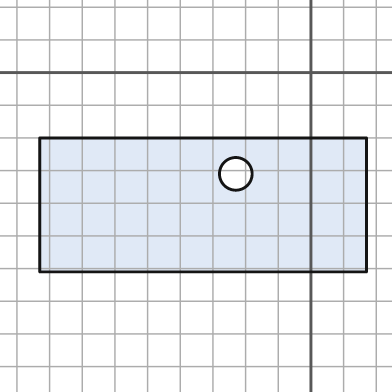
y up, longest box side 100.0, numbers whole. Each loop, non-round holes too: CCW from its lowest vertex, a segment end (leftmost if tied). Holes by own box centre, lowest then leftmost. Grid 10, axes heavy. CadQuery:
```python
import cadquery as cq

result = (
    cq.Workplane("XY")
    .moveTo(-83.0, -61.0)
    .lineTo(17.0, -61.0)
    .lineTo(17.0, -20.0)
    .lineTo(-83.0, -20.0)
    .close()
    .moveTo(-23.0, -31.0)
    .circle(5.0)
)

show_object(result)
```